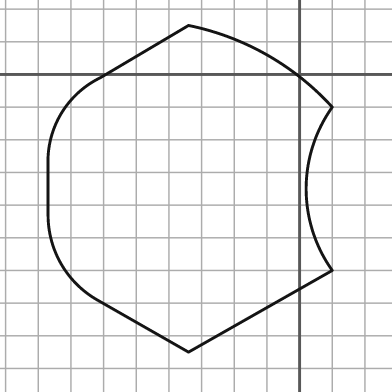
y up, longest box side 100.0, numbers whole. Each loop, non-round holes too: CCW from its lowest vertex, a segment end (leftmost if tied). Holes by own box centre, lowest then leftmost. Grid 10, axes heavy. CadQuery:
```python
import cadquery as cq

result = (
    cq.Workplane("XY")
    .moveTo(-34.0, -85.0)
    .lineTo(10.0, -60.0)
    .threePointArc((2.0, -35.0), (10.0, -10.0))
    .threePointArc((-10.0, 6.0), (-34.0, 15.0))
    .lineTo(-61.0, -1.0)
    .threePointArc((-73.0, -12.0), (-77.0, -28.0))
    .lineTo(-77.0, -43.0)
    .threePointArc((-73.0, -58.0), (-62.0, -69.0))
    .close()
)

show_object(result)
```